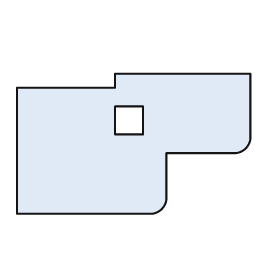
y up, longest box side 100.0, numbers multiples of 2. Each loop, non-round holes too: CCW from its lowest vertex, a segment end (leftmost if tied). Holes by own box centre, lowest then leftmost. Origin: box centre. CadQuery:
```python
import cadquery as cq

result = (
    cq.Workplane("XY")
    .moveTo(-50.0, -30.0)
    .lineTo(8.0, -30.0)
    .threePointArc((12.0, -28.0), (14.0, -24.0))
    .lineTo(14.0, -4.0)
    .lineTo(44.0, -4.0)
    .threePointArc((48.0, -2.0), (50.0, 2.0))
    .lineTo(50.0, 30.0)
    .lineTo(-8.0, 30.0)
    .lineTo(-8.0, 24.0)
    .lineTo(-50.0, 24.0)
    .close()
    .moveTo(-8.0, 4.0)
    .lineTo(4.0, 4.0)
    .lineTo(4.0, 16.0)
    .lineTo(-8.0, 16.0)
    .close()
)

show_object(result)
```